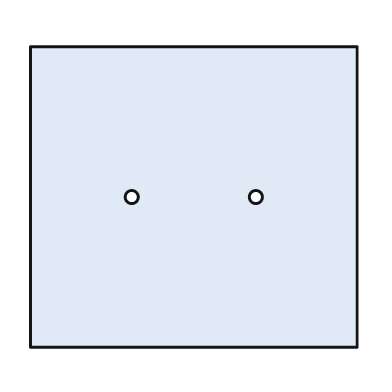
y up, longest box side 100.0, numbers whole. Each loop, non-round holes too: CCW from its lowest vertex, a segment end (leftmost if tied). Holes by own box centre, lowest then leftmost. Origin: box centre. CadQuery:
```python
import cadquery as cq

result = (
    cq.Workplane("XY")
    .moveTo(-50.0, -46.0)
    .lineTo(50.0, -46.0)
    .lineTo(50.0, 46.0)
    .lineTo(-50.0, 46.0)
    .close()
    .moveTo(-19.0, 0.0)
    .circle(2.0)
    .moveTo(19.0, 0.0)
    .circle(2.0)
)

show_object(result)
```